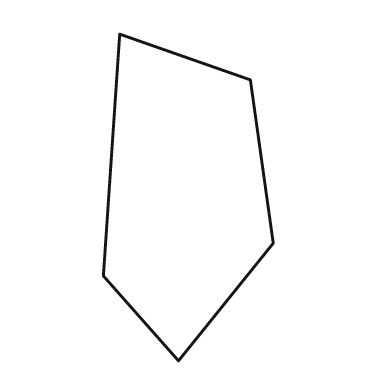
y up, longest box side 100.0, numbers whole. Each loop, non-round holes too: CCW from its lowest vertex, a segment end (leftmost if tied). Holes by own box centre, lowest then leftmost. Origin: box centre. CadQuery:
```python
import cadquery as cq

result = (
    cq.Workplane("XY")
    .moveTo(-3.0, -50.0)
    .lineTo(26.0, -14.0)
    .lineTo(19.0, 36.0)
    .lineTo(-21.0, 50.0)
    .lineTo(-26.0, -24.0)
    .close()
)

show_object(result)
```